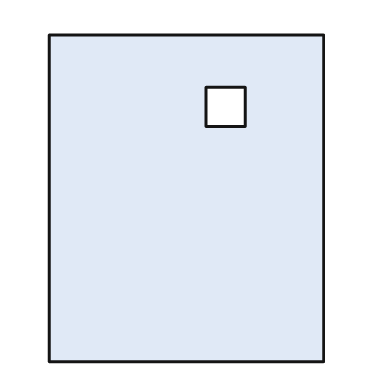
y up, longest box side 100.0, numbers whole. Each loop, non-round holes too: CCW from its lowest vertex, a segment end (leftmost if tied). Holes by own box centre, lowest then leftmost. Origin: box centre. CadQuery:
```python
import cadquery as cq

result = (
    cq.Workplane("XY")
    .moveTo(-42.0, -50.0)
    .lineTo(42.0, -50.0)
    .lineTo(42.0, 50.0)
    .lineTo(-42.0, 50.0)
    .close()
    .moveTo(6.0, 22.0)
    .lineTo(18.0, 22.0)
    .lineTo(18.0, 34.0)
    .lineTo(6.0, 34.0)
    .close()
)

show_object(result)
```